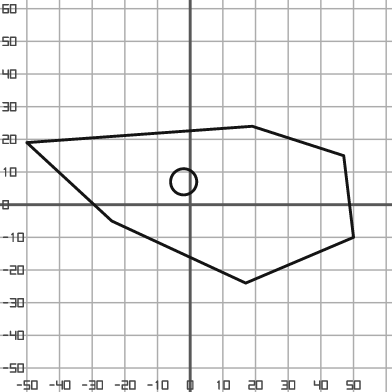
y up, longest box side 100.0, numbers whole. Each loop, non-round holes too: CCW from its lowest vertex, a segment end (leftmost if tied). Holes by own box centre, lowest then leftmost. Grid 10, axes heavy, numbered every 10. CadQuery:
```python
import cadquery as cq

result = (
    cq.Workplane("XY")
    .moveTo(17.0, -24.0)
    .lineTo(50.0, -10.0)
    .lineTo(47.0, 15.0)
    .lineTo(19.0, 24.0)
    .lineTo(-50.0, 19.0)
    .lineTo(-24.0, -5.0)
    .close()
    .moveTo(-2.0, 7.0)
    .circle(4.0)
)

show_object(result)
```